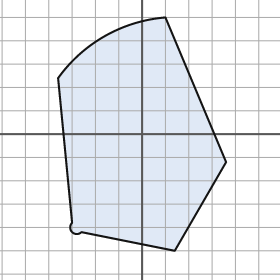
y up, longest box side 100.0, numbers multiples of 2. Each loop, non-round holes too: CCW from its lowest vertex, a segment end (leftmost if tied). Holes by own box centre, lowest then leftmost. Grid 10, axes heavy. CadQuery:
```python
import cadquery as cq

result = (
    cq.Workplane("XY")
    .moveTo(14.0, -50.0)
    .lineTo(36.0, -12.0)
    .lineTo(10.0, 50.0)
    .threePointArc((-16.0, 42.0), (-36.0, 24.0))
    .lineTo(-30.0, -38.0)
    .threePointArc((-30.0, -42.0), (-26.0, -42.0))
    .close()
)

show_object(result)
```